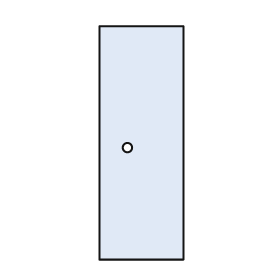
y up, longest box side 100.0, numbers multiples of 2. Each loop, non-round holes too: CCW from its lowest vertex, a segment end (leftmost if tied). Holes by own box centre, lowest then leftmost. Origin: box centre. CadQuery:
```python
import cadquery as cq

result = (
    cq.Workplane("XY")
    .moveTo(-18.0, -50.0)
    .lineTo(18.0, -50.0)
    .lineTo(18.0, 50.0)
    .lineTo(-18.0, 50.0)
    .close()
    .moveTo(-6.0, -2.0)
    .circle(2.0)
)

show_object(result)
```